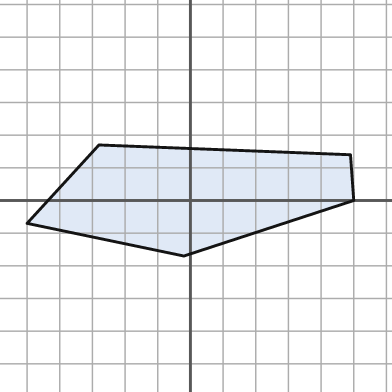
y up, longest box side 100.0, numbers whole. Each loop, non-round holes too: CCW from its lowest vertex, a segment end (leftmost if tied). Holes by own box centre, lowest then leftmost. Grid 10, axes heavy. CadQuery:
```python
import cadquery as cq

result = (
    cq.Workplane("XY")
    .moveTo(-2.0, -17.0)
    .lineTo(50.0, 0.0)
    .lineTo(49.0, 14.0)
    .lineTo(-28.0, 17.0)
    .lineTo(-50.0, -7.0)
    .close()
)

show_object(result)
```